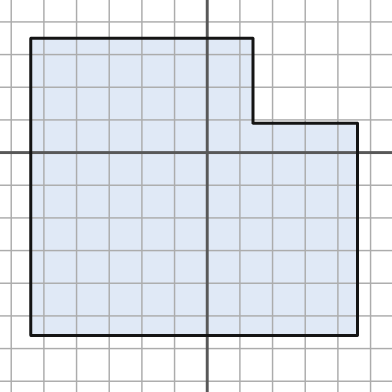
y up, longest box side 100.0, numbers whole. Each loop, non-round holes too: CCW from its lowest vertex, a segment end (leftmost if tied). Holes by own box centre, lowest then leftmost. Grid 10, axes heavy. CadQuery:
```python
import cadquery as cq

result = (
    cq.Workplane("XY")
    .moveTo(-54.0, -56.0)
    .lineTo(46.0, -56.0)
    .lineTo(46.0, 9.0)
    .lineTo(14.0, 9.0)
    .lineTo(14.0, 35.0)
    .lineTo(-54.0, 35.0)
    .close()
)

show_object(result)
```